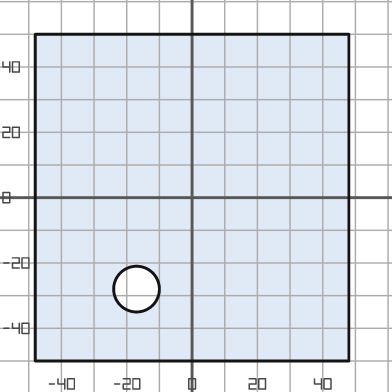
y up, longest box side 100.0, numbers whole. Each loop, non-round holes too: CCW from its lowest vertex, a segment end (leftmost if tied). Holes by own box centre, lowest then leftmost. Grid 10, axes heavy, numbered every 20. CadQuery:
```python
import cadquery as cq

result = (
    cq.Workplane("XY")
    .moveTo(-48.0, -50.0)
    .lineTo(48.0, -50.0)
    .lineTo(48.0, 50.0)
    .lineTo(-48.0, 50.0)
    .close()
    .moveTo(-17.0, -28.0)
    .circle(7.0)
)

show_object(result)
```